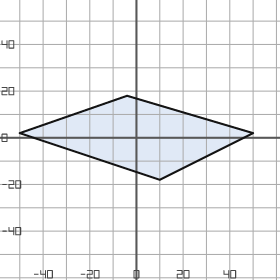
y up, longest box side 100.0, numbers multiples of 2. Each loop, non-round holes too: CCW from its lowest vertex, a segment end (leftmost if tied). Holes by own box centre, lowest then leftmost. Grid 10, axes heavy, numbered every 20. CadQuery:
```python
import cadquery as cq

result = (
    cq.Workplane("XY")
    .moveTo(10.0, -18.0)
    .lineTo(50.0, 2.0)
    .lineTo(-4.0, 18.0)
    .lineTo(-50.0, 2.0)
    .close()
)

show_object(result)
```